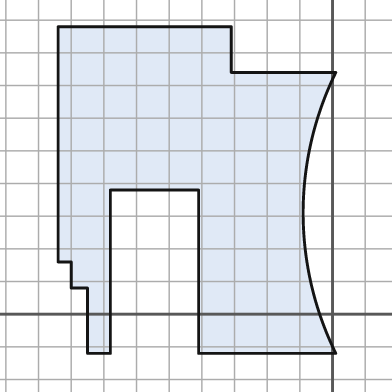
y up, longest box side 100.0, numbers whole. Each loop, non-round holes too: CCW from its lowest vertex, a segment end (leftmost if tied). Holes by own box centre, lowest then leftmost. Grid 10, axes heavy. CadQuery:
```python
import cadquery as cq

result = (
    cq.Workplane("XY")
    .moveTo(-75.0, -12.0)
    .lineTo(-68.0, -12.0)
    .lineTo(-68.0, 38.0)
    .lineTo(-41.0, 38.0)
    .lineTo(-41.0, -12.0)
    .lineTo(1.0, -12.0)
    .threePointArc((-9.0, 31.0), (1.0, 74.0))
    .lineTo(-31.0, 74.0)
    .lineTo(-31.0, 88.0)
    .lineTo(-84.0, 88.0)
    .lineTo(-84.0, 16.0)
    .lineTo(-80.0, 16.0)
    .lineTo(-80.0, 8.0)
    .lineTo(-75.0, 8.0)
    .close()
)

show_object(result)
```